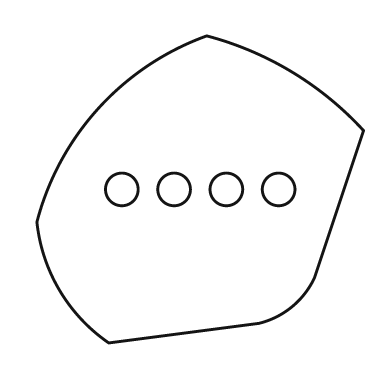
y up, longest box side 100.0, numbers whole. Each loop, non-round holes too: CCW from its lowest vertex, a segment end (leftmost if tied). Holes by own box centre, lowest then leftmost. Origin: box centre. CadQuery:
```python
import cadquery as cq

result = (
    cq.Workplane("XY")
    .moveTo(-28.0, -47.0)
    .lineTo(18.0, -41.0)
    .threePointArc((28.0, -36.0), (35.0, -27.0))
    .lineTo(50.0, 18.0)
    .threePointArc((28.0, 36.0), (2.0, 47.0))
    .threePointArc((-31.0, 25.0), (-50.0, -10.0))
    .threePointArc((-43.0, -31.0), (-28.0, -47.0))
    .close()
    .moveTo(-24.0, 0.0)
    .circle(5.0)
    .moveTo(-8.0, 0.0)
    .circle(5.0)
    .moveTo(8.0, 0.0)
    .circle(5.0)
    .moveTo(24.0, 0.0)
    .circle(5.0)
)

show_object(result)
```